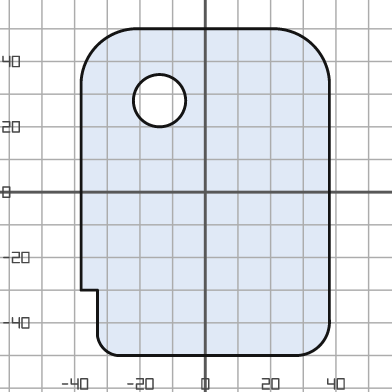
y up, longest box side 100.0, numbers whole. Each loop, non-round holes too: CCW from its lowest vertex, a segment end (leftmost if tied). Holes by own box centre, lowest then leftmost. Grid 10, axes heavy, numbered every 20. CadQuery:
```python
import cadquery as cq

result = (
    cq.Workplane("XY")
    .moveTo(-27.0, -50.0)
    .lineTo(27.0, -50.0)
    .threePointArc((35.0, -47.0), (38.0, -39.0))
    .lineTo(38.0, 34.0)
    .threePointArc((33.0, 45.0), (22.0, 50.0))
    .lineTo(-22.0, 50.0)
    .threePointArc((-33.0, 45.0), (-38.0, 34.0))
    .lineTo(-38.0, -30.0)
    .lineTo(-33.0, -30.0)
    .lineTo(-33.0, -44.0)
    .threePointArc((-31.0, -48.0), (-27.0, -50.0))
    .close()
    .moveTo(-14.0, 28.0)
    .circle(8.0)
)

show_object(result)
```